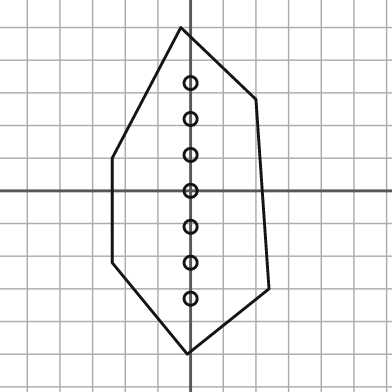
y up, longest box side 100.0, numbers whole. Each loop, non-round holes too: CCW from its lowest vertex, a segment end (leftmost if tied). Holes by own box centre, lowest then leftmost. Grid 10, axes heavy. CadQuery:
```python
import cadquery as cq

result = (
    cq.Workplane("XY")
    .moveTo(-1.0, -50.0)
    .lineTo(24.0, -30.0)
    .lineTo(20.0, 28.0)
    .lineTo(-3.0, 50.0)
    .lineTo(-24.0, 10.0)
    .lineTo(-24.0, -22.0)
    .close()
    .moveTo(0.0, -33.0)
    .circle(2.0)
    .moveTo(0.0, -22.0)
    .circle(2.0)
    .moveTo(0.0, -11.0)
    .circle(2.0)
    .moveTo(0.0, 0.0)
    .circle(2.0)
    .moveTo(0.0, 11.0)
    .circle(2.0)
    .moveTo(0.0, 22.0)
    .circle(2.0)
    .moveTo(0.0, 33.0)
    .circle(2.0)
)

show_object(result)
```